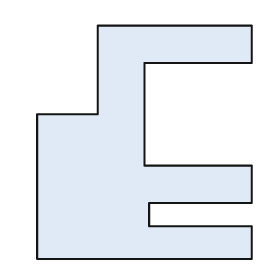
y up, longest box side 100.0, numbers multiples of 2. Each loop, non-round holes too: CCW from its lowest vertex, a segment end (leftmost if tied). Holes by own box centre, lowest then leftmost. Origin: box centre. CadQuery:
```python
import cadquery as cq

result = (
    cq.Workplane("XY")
    .moveTo(-46.0, -50.0)
    .lineTo(46.0, -50.0)
    .lineTo(46.0, -36.0)
    .lineTo(2.0, -36.0)
    .lineTo(2.0, -26.0)
    .lineTo(46.0, -26.0)
    .lineTo(46.0, -10.0)
    .lineTo(0.0, -10.0)
    .lineTo(0.0, 34.0)
    .lineTo(46.0, 34.0)
    .lineTo(46.0, 50.0)
    .lineTo(-20.0, 50.0)
    .lineTo(-20.0, 12.0)
    .lineTo(-46.0, 12.0)
    .close()
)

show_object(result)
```